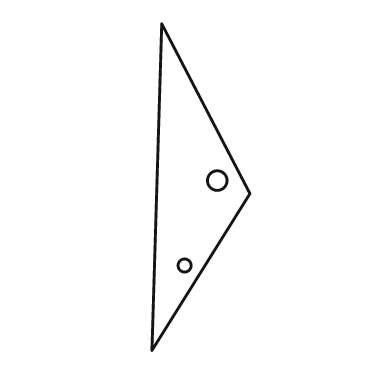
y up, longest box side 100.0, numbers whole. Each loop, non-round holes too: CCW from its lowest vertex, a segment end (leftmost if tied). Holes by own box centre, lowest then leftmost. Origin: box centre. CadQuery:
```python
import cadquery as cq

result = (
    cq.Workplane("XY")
    .moveTo(-15.0, -50.0)
    .lineTo(15.0, -2.0)
    .lineTo(-12.0, 50.0)
    .close()
    .moveTo(-5.0, -24.0)
    .circle(2.0)
    .moveTo(5.0, 2.0)
    .circle(3.0)
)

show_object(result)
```